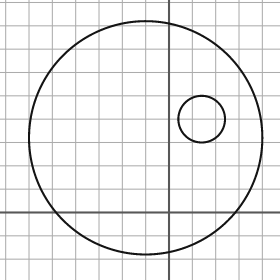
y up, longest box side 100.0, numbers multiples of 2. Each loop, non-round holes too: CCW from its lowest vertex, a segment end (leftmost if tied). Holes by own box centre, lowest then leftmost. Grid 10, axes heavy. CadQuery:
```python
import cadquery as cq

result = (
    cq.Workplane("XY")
    .moveTo(-10.0, 32.0)
    .circle(50.0)
    .moveTo(14.0, 40.0)
    .circle(10.0)
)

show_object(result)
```